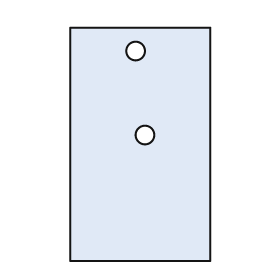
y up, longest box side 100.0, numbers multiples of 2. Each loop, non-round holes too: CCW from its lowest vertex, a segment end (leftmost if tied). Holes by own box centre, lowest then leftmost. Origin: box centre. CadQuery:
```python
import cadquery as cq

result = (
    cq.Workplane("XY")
    .moveTo(-30.0, -50.0)
    .lineTo(30.0, -50.0)
    .lineTo(30.0, 50.0)
    .lineTo(-30.0, 50.0)
    .close()
    .moveTo(2.0, 4.0)
    .circle(4.0)
    .moveTo(-2.0, 40.0)
    .circle(4.0)
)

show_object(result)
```